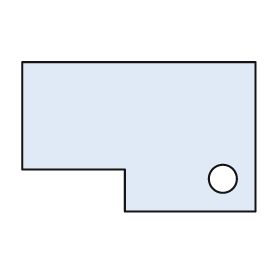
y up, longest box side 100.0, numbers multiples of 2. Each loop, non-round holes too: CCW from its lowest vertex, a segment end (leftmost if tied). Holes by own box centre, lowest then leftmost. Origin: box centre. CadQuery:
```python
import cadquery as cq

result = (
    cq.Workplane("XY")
    .moveTo(-6.0, -32.0)
    .lineTo(50.0, -32.0)
    .lineTo(50.0, 32.0)
    .lineTo(-50.0, 32.0)
    .lineTo(-50.0, -14.0)
    .lineTo(-6.0, -14.0)
    .close()
    .moveTo(36.0, -18.0)
    .circle(6.0)
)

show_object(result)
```